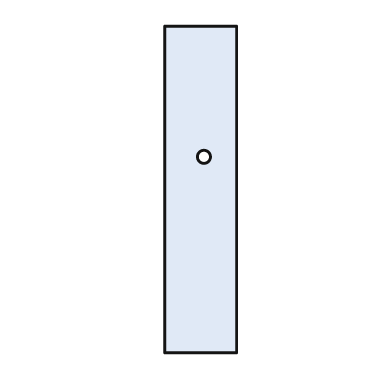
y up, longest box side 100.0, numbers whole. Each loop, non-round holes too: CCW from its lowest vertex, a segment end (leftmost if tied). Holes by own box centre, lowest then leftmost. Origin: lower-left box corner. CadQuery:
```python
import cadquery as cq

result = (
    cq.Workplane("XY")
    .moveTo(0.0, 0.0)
    .lineTo(22.0, 0.0)
    .lineTo(22.0, 100.0)
    .lineTo(0.0, 100.0)
    .close()
    .moveTo(12.0, 60.0)
    .circle(2.0)
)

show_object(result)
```